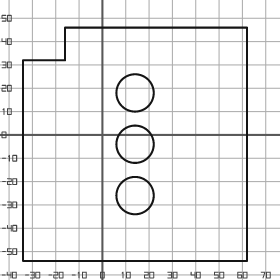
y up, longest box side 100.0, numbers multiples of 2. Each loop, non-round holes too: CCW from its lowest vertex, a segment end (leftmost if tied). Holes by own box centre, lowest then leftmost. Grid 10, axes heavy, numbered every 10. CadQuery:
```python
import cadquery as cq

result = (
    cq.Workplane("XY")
    .moveTo(-34.0, -54.0)
    .lineTo(62.0, -54.0)
    .lineTo(62.0, 46.0)
    .lineTo(-16.0, 46.0)
    .lineTo(-16.0, 32.0)
    .lineTo(-34.0, 32.0)
    .close()
    .moveTo(14.0, -26.0)
    .circle(8.0)
    .moveTo(14.0, -4.0)
    .circle(8.0)
    .moveTo(14.0, 18.0)
    .circle(8.0)
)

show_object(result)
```